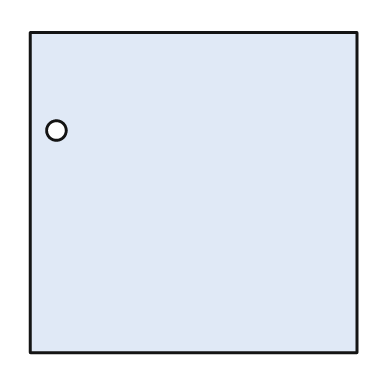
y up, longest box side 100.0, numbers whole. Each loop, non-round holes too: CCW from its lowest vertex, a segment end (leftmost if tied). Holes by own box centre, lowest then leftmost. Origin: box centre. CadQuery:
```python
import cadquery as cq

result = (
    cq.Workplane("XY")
    .moveTo(-50.0, -49.0)
    .lineTo(50.0, -49.0)
    .lineTo(50.0, 49.0)
    .lineTo(-50.0, 49.0)
    .close()
    .moveTo(-42.0, 19.0)
    .circle(3.0)
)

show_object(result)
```